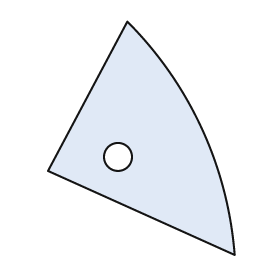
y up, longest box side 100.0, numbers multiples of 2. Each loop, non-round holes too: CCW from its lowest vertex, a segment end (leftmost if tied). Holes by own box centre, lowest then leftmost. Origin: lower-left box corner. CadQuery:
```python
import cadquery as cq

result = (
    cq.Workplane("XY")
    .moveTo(80.0, 0.0)
    .threePointArc((66.0, 54.0), (34.0, 100.0))
    .lineTo(0.0, 36.0)
    .close()
    .moveTo(30.0, 42.0)
    .circle(6.0)
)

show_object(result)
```